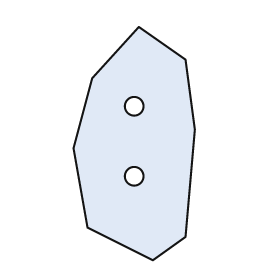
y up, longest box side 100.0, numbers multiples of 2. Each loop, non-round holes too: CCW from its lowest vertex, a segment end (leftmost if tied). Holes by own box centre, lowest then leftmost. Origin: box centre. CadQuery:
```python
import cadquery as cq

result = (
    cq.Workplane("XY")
    .moveTo(8.0, -50.0)
    .lineTo(22.0, -40.0)
    .lineTo(26.0, 6.0)
    .lineTo(22.0, 36.0)
    .lineTo(2.0, 50.0)
    .lineTo(-18.0, 28.0)
    .lineTo(-26.0, -2.0)
    .lineTo(-20.0, -36.0)
    .close()
    .moveTo(0.0, -14.0)
    .circle(4.0)
    .moveTo(0.0, 16.0)
    .circle(4.0)
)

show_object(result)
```